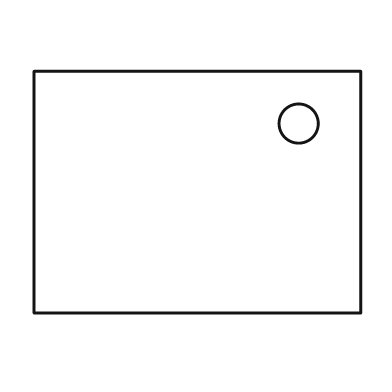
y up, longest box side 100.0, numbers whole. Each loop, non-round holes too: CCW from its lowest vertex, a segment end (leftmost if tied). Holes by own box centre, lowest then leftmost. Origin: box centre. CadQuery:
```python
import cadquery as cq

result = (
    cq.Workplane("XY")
    .moveTo(-50.0, -37.0)
    .lineTo(50.0, -37.0)
    .lineTo(50.0, 37.0)
    .lineTo(-50.0, 37.0)
    .close()
    .moveTo(31.0, 21.0)
    .circle(6.0)
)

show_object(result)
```